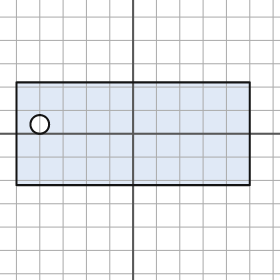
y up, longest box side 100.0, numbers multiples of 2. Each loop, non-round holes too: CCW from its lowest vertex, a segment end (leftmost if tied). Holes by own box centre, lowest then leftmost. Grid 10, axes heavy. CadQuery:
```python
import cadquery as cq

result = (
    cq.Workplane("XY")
    .moveTo(-50.0, -22.0)
    .lineTo(50.0, -22.0)
    .lineTo(50.0, 22.0)
    .lineTo(-50.0, 22.0)
    .close()
    .moveTo(-40.0, 4.0)
    .circle(4.0)
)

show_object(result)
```